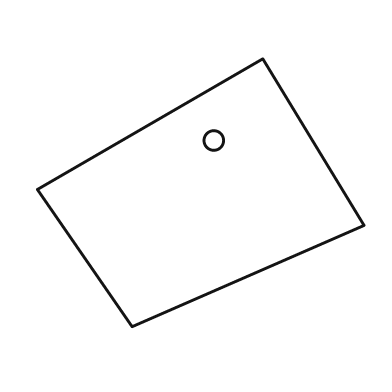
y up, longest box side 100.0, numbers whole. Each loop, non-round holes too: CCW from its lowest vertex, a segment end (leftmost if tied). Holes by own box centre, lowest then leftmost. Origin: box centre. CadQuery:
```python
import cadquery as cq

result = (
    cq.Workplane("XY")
    .moveTo(-21.0, -41.0)
    .lineTo(50.0, -10.0)
    .lineTo(19.0, 41.0)
    .lineTo(-50.0, 1.0)
    .close()
    .moveTo(4.0, 16.0)
    .circle(3.0)
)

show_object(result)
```